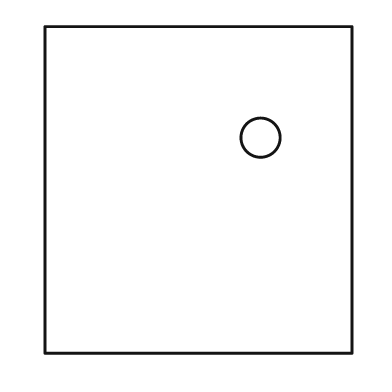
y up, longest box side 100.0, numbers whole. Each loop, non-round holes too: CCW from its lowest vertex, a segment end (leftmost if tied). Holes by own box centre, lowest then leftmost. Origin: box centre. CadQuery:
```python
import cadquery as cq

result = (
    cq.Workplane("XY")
    .moveTo(-47.0, -50.0)
    .lineTo(47.0, -50.0)
    .lineTo(47.0, 50.0)
    .lineTo(-47.0, 50.0)
    .close()
    .moveTo(19.0, 16.0)
    .circle(6.0)
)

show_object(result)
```